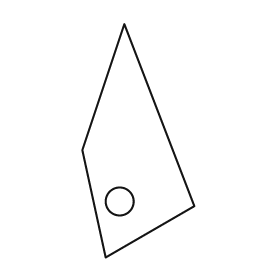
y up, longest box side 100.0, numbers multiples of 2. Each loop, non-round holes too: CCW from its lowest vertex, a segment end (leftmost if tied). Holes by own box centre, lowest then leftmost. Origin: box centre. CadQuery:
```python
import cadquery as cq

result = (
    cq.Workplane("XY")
    .moveTo(-14.0, -50.0)
    .lineTo(24.0, -28.0)
    .lineTo(-6.0, 50.0)
    .lineTo(-24.0, -4.0)
    .close()
    .moveTo(-8.0, -26.0)
    .circle(6.0)
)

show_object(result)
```